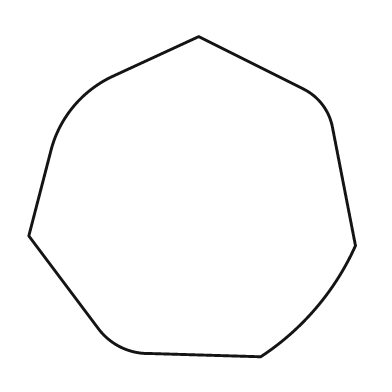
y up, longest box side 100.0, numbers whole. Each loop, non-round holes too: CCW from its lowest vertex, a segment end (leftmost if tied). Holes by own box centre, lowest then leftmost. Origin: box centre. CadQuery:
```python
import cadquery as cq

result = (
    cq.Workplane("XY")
    .moveTo(21.0, -49.0)
    .threePointArc((38.0, -34.0), (50.0, -15.0))
    .lineTo(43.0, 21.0)
    .threePointArc((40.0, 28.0), (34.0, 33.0))
    .lineTo(2.0, 49.0)
    .lineTo(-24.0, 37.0)
    .threePointArc((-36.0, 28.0), (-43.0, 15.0))
    .lineTo(-50.0, -12.0)
    .lineTo(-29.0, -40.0)
    .threePointArc((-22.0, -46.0), (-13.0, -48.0))
    .close()
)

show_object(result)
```